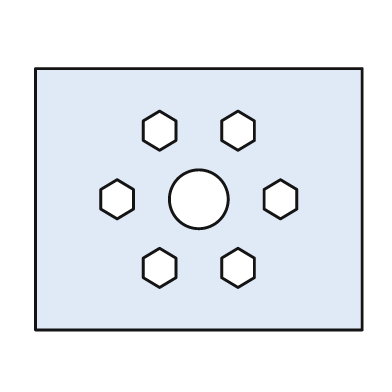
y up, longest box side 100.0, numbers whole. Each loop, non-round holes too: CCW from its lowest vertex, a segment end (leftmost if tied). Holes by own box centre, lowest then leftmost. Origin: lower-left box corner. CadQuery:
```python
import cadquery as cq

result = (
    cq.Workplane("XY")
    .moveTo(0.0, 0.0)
    .lineTo(100.0, 0.0)
    .lineTo(100.0, 80.0)
    .lineTo(0.0, 80.0)
    .close()
    .moveTo(38.0, 13.0)
    .lineTo(43.0, 16.0)
    .lineTo(43.0, 22.0)
    .lineTo(38.0, 25.0)
    .lineTo(33.0, 22.0)
    .lineTo(33.0, 16.0)
    .close()
    .moveTo(62.0, 13.0)
    .lineTo(67.0, 16.0)
    .lineTo(67.0, 22.0)
    .lineTo(62.0, 25.0)
    .lineTo(57.0, 22.0)
    .lineTo(57.0, 16.0)
    .close()
    .moveTo(25.0, 34.0)
    .lineTo(30.0, 37.0)
    .lineTo(30.0, 43.0)
    .lineTo(25.0, 46.0)
    .lineTo(20.0, 43.0)
    .lineTo(20.0, 37.0)
    .close()
    .moveTo(50.0, 40.0)
    .circle(9.0)
    .moveTo(75.0, 34.0)
    .lineTo(80.0, 37.0)
    .lineTo(80.0, 43.0)
    .lineTo(75.0, 46.0)
    .lineTo(70.0, 43.0)
    .lineTo(70.0, 37.0)
    .close()
    .moveTo(38.0, 55.0)
    .lineTo(43.0, 58.0)
    .lineTo(43.0, 64.0)
    .lineTo(38.0, 67.0)
    .lineTo(33.0, 64.0)
    .lineTo(33.0, 58.0)
    .close()
    .moveTo(62.0, 55.0)
    .lineTo(67.0, 58.0)
    .lineTo(67.0, 64.0)
    .lineTo(62.0, 67.0)
    .lineTo(57.0, 64.0)
    .lineTo(57.0, 58.0)
    .close()
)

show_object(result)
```